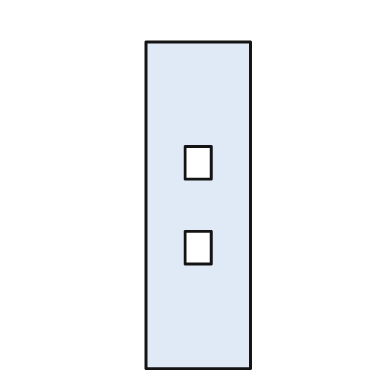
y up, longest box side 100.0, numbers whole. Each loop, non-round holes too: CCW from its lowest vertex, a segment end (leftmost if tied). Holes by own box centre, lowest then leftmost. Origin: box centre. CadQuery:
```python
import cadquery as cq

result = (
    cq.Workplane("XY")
    .moveTo(-16.0, -50.0)
    .lineTo(16.0, -50.0)
    .lineTo(16.0, 50.0)
    .lineTo(-16.0, 50.0)
    .close()
    .moveTo(-4.0, -18.0)
    .lineTo(4.0, -18.0)
    .lineTo(4.0, -8.0)
    .lineTo(-4.0, -8.0)
    .close()
    .moveTo(-4.0, 8.0)
    .lineTo(4.0, 8.0)
    .lineTo(4.0, 18.0)
    .lineTo(-4.0, 18.0)
    .close()
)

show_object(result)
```